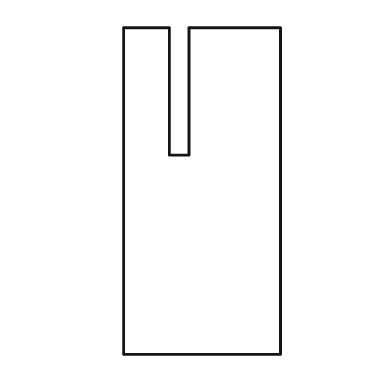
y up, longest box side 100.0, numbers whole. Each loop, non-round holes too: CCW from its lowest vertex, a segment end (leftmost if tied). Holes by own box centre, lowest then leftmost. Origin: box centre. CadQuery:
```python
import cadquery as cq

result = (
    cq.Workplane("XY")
    .moveTo(-24.0, -50.0)
    .lineTo(24.0, -50.0)
    .lineTo(24.0, 50.0)
    .lineTo(-4.0, 50.0)
    .lineTo(-4.0, 11.0)
    .lineTo(-10.0, 11.0)
    .lineTo(-10.0, 50.0)
    .lineTo(-24.0, 50.0)
    .close()
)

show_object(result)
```